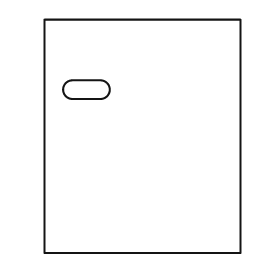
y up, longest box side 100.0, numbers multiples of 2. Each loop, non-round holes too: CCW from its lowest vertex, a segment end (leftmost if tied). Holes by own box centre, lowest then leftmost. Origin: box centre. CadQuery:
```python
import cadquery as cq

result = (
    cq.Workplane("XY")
    .moveTo(-42.0, -50.0)
    .lineTo(42.0, -50.0)
    .lineTo(42.0, 50.0)
    .lineTo(-42.0, 50.0)
    .close()
    .moveTo(-30.0, 16.0)
    .lineTo(-18.0, 16.0)
    .threePointArc((-14.0, 20.0), (-18.0, 24.0))
    .lineTo(-30.0, 24.0)
    .threePointArc((-34.0, 20.0), (-30.0, 16.0))
    .close()
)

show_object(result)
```